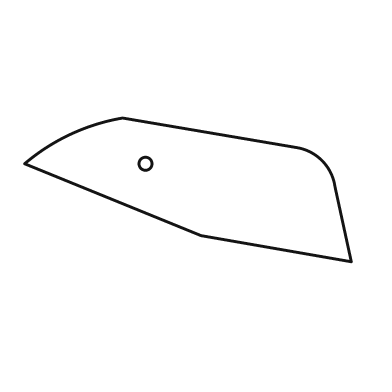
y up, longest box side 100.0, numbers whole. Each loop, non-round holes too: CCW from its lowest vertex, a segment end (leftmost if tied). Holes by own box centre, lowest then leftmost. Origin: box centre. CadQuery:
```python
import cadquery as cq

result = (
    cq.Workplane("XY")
    .moveTo(50.0, -22.0)
    .lineTo(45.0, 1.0)
    .threePointArc((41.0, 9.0), (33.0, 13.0))
    .lineTo(-20.0, 22.0)
    .threePointArc((-36.0, 17.0), (-50.0, 8.0))
    .lineTo(4.0, -14.0)
    .close()
    .moveTo(-13.0, 8.0)
    .circle(2.0)
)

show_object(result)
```